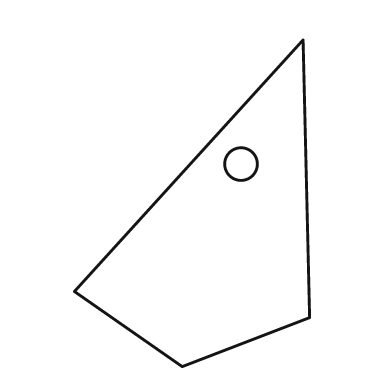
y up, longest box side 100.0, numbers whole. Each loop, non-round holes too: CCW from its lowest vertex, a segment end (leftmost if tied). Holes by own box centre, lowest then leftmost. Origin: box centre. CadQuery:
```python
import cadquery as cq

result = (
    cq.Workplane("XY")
    .moveTo(-3.0, -50.0)
    .lineTo(36.0, -35.0)
    .lineTo(34.0, 50.0)
    .lineTo(-36.0, -27.0)
    .close()
    .moveTo(15.0, 12.0)
    .circle(5.0)
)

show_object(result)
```